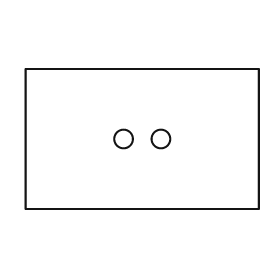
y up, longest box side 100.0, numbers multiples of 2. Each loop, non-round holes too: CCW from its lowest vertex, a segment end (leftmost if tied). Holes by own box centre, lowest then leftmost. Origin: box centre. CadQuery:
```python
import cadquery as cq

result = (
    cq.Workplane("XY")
    .moveTo(-50.0, -30.0)
    .lineTo(50.0, -30.0)
    .lineTo(50.0, 30.0)
    .lineTo(-50.0, 30.0)
    .close()
    .moveTo(-8.0, 0.0)
    .circle(4.0)
    .moveTo(8.0, 0.0)
    .circle(4.0)
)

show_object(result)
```